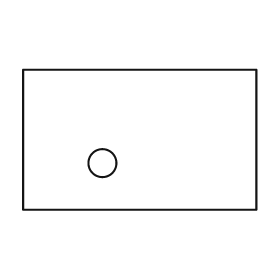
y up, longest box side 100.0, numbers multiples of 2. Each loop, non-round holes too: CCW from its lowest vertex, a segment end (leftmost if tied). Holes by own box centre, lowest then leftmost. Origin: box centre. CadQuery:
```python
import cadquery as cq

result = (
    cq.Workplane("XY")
    .moveTo(-50.0, -30.0)
    .lineTo(50.0, -30.0)
    .lineTo(50.0, 30.0)
    .lineTo(-50.0, 30.0)
    .close()
    .moveTo(-16.0, -10.0)
    .circle(6.0)
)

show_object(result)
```